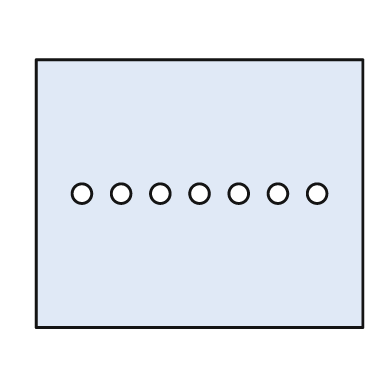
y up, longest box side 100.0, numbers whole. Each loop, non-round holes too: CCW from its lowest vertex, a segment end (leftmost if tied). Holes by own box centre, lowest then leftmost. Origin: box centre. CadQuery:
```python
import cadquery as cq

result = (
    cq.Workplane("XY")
    .moveTo(-50.0, -41.0)
    .lineTo(50.0, -41.0)
    .lineTo(50.0, 41.0)
    .lineTo(-50.0, 41.0)
    .close()
    .moveTo(-36.0, 0.0)
    .circle(3.0)
    .moveTo(-24.0, 0.0)
    .circle(3.0)
    .moveTo(-12.0, 0.0)
    .circle(3.0)
    .moveTo(0.0, 0.0)
    .circle(3.0)
    .moveTo(12.0, 0.0)
    .circle(3.0)
    .moveTo(24.0, 0.0)
    .circle(3.0)
    .moveTo(36.0, 0.0)
    .circle(3.0)
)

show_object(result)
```